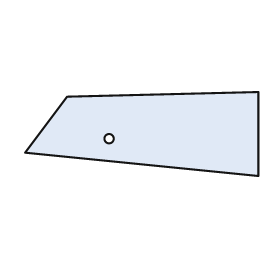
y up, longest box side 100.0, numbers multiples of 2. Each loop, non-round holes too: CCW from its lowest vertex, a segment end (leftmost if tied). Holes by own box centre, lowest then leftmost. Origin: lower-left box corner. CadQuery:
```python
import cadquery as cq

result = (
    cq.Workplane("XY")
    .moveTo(100.0, 0.0)
    .lineTo(100.0, 36.0)
    .lineTo(18.0, 34.0)
    .lineTo(0.0, 10.0)
    .close()
    .moveTo(36.0, 16.0)
    .circle(2.0)
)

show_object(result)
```